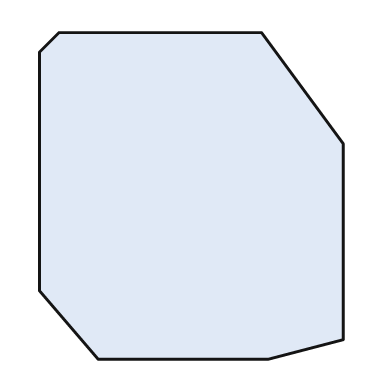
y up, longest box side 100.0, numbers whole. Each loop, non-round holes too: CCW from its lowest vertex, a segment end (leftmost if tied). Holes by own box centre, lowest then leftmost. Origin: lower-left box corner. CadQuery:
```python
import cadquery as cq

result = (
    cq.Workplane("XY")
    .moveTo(18.0, 0.0)
    .lineTo(70.0, 0.0)
    .lineTo(93.0, 6.0)
    .lineTo(93.0, 66.0)
    .lineTo(68.0, 100.0)
    .lineTo(6.0, 100.0)
    .lineTo(0.0, 94.0)
    .lineTo(0.0, 21.0)
    .close()
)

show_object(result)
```